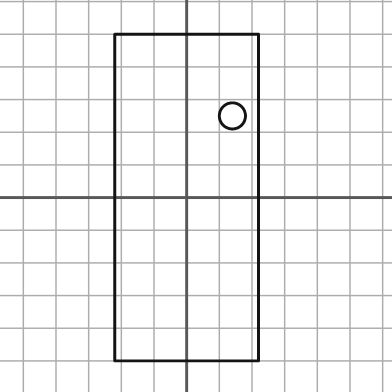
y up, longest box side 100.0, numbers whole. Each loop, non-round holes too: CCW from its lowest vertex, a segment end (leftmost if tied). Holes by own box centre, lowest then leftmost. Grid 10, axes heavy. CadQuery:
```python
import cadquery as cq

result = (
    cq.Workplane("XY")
    .moveTo(-22.0, -50.0)
    .lineTo(22.0, -50.0)
    .lineTo(22.0, 50.0)
    .lineTo(-22.0, 50.0)
    .close()
    .moveTo(14.0, 25.0)
    .circle(4.0)
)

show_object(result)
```